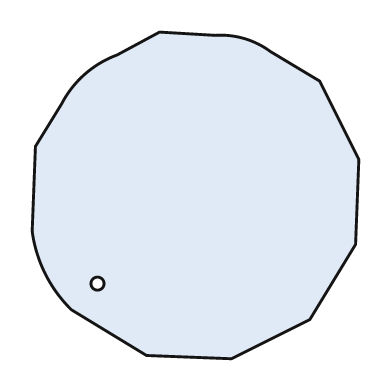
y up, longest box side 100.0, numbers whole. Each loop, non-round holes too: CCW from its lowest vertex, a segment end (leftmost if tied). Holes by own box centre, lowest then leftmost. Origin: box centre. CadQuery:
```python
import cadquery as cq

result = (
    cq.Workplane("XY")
    .moveTo(11.0, -50.0)
    .lineTo(35.0, -38.0)
    .lineTo(49.0, -15.0)
    .lineTo(50.0, 11.0)
    .lineTo(38.0, 35.0)
    .lineTo(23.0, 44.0)
    .threePointArc((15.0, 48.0), (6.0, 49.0))
    .lineTo(-11.0, 50.0)
    .lineTo(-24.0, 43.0)
    .threePointArc((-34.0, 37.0), (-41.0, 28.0))
    .lineTo(-49.0, 15.0)
    .lineTo(-50.0, -11.0)
    .threePointArc((-46.0, -24.0), (-38.0, -35.0))
    .lineTo(-15.0, -49.0)
    .close()
    .moveTo(-30.0, -27.0)
    .circle(2.0)
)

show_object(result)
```